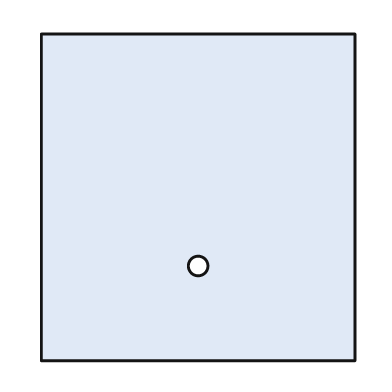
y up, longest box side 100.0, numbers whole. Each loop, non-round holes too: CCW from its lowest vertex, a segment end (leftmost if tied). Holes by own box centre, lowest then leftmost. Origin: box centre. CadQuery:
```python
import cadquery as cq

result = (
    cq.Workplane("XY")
    .moveTo(-48.0, -50.0)
    .lineTo(48.0, -50.0)
    .lineTo(48.0, 50.0)
    .lineTo(-48.0, 50.0)
    .close()
    .moveTo(0.0, -21.0)
    .circle(3.0)
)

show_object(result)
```